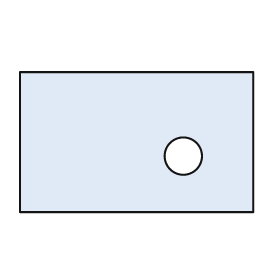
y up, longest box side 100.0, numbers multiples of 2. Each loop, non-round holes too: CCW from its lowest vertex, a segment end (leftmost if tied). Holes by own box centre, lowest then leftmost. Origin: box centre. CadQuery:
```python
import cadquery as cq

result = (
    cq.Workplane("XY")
    .moveTo(-50.0, -30.0)
    .lineTo(50.0, -30.0)
    .lineTo(50.0, 30.0)
    .lineTo(-50.0, 30.0)
    .close()
    .moveTo(20.0, -6.0)
    .circle(8.0)
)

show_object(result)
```